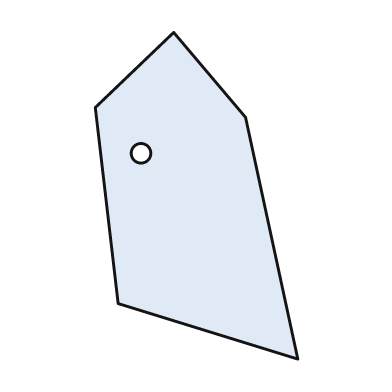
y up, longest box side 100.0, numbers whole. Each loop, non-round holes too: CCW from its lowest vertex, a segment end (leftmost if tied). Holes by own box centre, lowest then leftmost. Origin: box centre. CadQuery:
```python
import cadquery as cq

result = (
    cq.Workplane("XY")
    .moveTo(31.0, -50.0)
    .lineTo(15.0, 24.0)
    .lineTo(-7.0, 50.0)
    .lineTo(-31.0, 27.0)
    .lineTo(-24.0, -33.0)
    .close()
    .moveTo(-17.0, 13.0)
    .circle(3.0)
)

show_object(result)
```